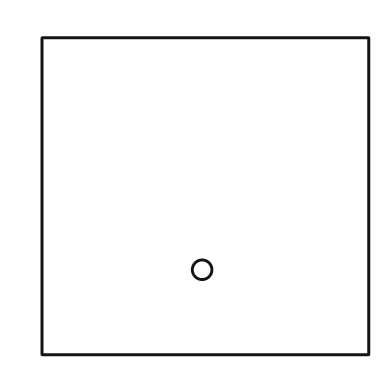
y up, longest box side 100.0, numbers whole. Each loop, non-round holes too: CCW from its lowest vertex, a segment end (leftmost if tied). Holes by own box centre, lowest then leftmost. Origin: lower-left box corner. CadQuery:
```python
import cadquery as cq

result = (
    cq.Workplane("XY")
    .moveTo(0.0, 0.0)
    .lineTo(100.0, 0.0)
    .lineTo(100.0, 97.0)
    .lineTo(0.0, 97.0)
    .close()
    .moveTo(49.0, 26.0)
    .circle(3.0)
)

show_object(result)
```